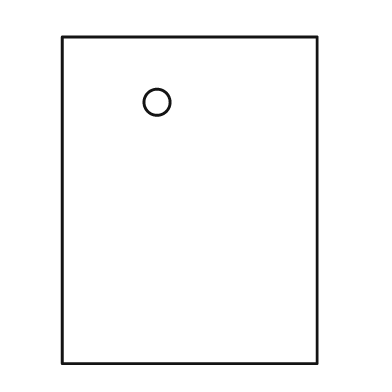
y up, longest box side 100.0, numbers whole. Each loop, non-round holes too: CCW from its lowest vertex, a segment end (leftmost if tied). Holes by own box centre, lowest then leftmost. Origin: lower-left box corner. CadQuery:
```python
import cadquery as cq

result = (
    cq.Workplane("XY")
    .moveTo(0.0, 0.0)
    .lineTo(78.0, 0.0)
    .lineTo(78.0, 100.0)
    .lineTo(0.0, 100.0)
    .close()
    .moveTo(29.0, 80.0)
    .circle(4.0)
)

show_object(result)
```